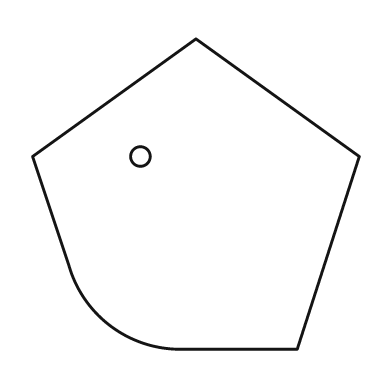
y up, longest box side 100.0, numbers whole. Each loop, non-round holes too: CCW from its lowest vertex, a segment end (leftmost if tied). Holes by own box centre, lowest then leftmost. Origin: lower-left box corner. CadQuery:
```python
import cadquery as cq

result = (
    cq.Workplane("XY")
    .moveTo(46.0, 0.0)
    .lineTo(81.0, 0.0)
    .lineTo(100.0, 59.0)
    .lineTo(50.0, 95.0)
    .lineTo(0.0, 59.0)
    .lineTo(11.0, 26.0)
    .threePointArc((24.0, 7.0), (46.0, 0.0))
    .close()
    .moveTo(33.0, 59.0)
    .circle(3.0)
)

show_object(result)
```